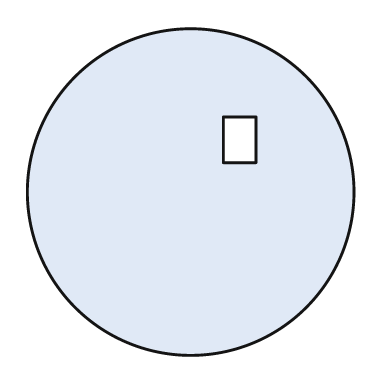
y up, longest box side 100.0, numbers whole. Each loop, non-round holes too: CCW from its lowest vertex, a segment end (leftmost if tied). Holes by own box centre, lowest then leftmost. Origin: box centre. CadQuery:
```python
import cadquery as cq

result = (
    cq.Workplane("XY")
    .moveTo(0.0, 0.0)
    .circle(50.0)
    .moveTo(10.0, 9.0)
    .lineTo(20.0, 9.0)
    .lineTo(20.0, 23.0)
    .lineTo(10.0, 23.0)
    .close()
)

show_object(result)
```